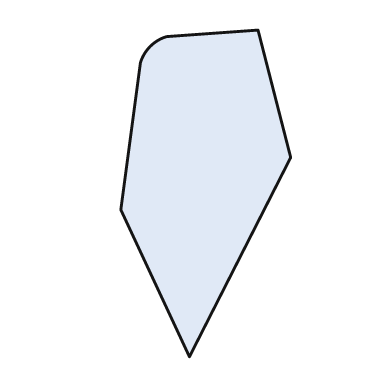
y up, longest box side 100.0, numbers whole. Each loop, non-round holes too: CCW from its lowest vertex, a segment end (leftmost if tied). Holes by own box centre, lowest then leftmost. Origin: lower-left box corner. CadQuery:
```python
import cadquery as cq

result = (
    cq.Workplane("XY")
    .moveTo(21.0, 0.0)
    .lineTo(52.0, 61.0)
    .lineTo(42.0, 100.0)
    .lineTo(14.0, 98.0)
    .threePointArc((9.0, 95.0), (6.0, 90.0))
    .lineTo(0.0, 45.0)
    .close()
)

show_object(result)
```